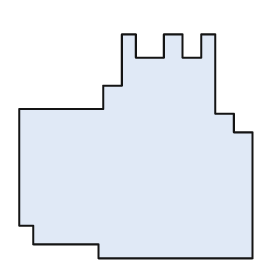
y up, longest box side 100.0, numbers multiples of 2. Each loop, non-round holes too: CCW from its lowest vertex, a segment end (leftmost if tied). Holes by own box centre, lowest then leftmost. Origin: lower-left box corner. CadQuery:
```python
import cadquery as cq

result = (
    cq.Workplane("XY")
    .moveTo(34.0, 0.0)
    .lineTo(100.0, 0.0)
    .lineTo(100.0, 54.0)
    .lineTo(92.0, 54.0)
    .lineTo(92.0, 62.0)
    .lineTo(84.0, 62.0)
    .lineTo(84.0, 96.0)
    .lineTo(78.0, 96.0)
    .lineTo(78.0, 86.0)
    .lineTo(70.0, 86.0)
    .lineTo(70.0, 96.0)
    .lineTo(62.0, 96.0)
    .lineTo(62.0, 86.0)
    .lineTo(50.0, 86.0)
    .lineTo(50.0, 96.0)
    .lineTo(44.0, 96.0)
    .lineTo(44.0, 74.0)
    .lineTo(36.0, 74.0)
    .lineTo(36.0, 64.0)
    .lineTo(0.0, 64.0)
    .lineTo(0.0, 14.0)
    .lineTo(6.0, 14.0)
    .lineTo(6.0, 6.0)
    .lineTo(34.0, 6.0)
    .close()
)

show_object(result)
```